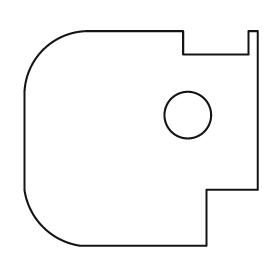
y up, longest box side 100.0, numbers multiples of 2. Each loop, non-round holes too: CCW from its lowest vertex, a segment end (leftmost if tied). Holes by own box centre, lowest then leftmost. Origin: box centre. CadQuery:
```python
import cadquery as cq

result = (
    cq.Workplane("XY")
    .moveTo(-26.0, -46.0)
    .lineTo(28.0, -46.0)
    .lineTo(28.0, -22.0)
    .lineTo(50.0, -22.0)
    .lineTo(50.0, 46.0)
    .lineTo(46.0, 46.0)
    .lineTo(46.0, 36.0)
    .lineTo(18.0, 36.0)
    .lineTo(18.0, 46.0)
    .lineTo(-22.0, 46.0)
    .threePointArc((-42.0, 38.0), (-50.0, 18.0))
    .lineTo(-50.0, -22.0)
    .threePointArc((-42.0, -38.0), (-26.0, -46.0))
    .close()
    .moveTo(20.0, 10.0)
    .circle(10.0)
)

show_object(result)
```